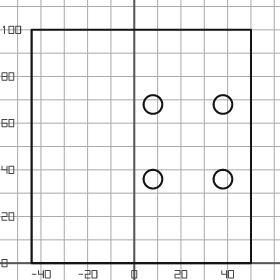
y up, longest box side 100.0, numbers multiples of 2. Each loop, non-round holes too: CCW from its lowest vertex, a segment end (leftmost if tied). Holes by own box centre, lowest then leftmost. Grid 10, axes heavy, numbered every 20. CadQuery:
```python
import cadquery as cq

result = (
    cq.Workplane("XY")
    .moveTo(-44.0, 0.0)
    .lineTo(50.0, 0.0)
    .lineTo(50.0, 100.0)
    .lineTo(-44.0, 100.0)
    .close()
    .moveTo(8.0, 36.0)
    .circle(4.0)
    .moveTo(38.0, 36.0)
    .circle(4.0)
    .moveTo(8.0, 68.0)
    .circle(4.0)
    .moveTo(38.0, 68.0)
    .circle(4.0)
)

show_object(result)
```